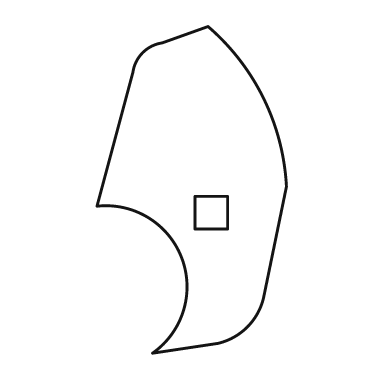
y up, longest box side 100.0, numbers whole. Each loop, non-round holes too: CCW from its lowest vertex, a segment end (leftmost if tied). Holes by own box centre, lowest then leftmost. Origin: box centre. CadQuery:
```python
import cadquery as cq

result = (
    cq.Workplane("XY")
    .moveTo(-12.0, -50.0)
    .lineTo(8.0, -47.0)
    .threePointArc((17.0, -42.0), (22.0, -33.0))
    .lineTo(29.0, 1.0)
    .threePointArc((22.0, 28.0), (5.0, 50.0))
    .lineTo(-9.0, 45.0)
    .threePointArc((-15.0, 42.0), (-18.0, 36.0))
    .lineTo(-29.0, -5.0)
    .threePointArc((-3.0, -21.0), (-12.0, -50.0))
    .close()
    .moveTo(1.0, -12.0)
    .lineTo(11.0, -12.0)
    .lineTo(11.0, -2.0)
    .lineTo(1.0, -2.0)
    .close()
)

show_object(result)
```